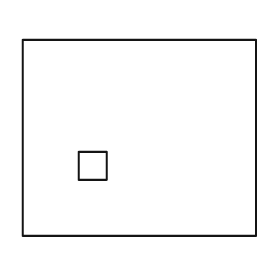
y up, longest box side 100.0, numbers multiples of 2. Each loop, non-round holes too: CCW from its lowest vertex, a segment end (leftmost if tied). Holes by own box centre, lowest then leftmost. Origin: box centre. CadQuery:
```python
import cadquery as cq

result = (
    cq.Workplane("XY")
    .moveTo(-50.0, -42.0)
    .lineTo(50.0, -42.0)
    .lineTo(50.0, 42.0)
    .lineTo(-50.0, 42.0)
    .close()
    .moveTo(-26.0, -18.0)
    .lineTo(-14.0, -18.0)
    .lineTo(-14.0, -6.0)
    .lineTo(-26.0, -6.0)
    .close()
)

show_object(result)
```